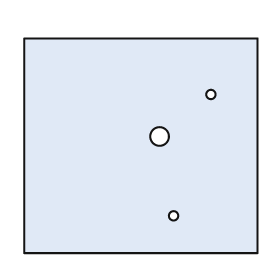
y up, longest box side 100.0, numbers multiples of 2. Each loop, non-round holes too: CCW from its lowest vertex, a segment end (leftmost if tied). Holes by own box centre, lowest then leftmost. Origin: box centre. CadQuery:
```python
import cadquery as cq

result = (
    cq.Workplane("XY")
    .moveTo(-50.0, -46.0)
    .lineTo(50.0, -46.0)
    .lineTo(50.0, 46.0)
    .lineTo(-50.0, 46.0)
    .close()
    .moveTo(14.0, -30.0)
    .circle(2.0)
    .moveTo(8.0, 4.0)
    .circle(4.0)
    .moveTo(30.0, 22.0)
    .circle(2.0)
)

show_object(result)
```